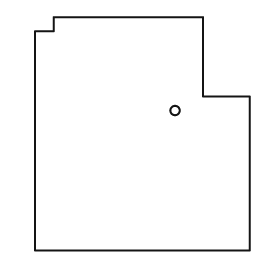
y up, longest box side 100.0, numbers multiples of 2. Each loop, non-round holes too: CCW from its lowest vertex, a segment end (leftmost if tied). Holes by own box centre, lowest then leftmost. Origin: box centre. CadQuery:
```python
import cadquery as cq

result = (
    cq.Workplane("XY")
    .moveTo(-46.0, -50.0)
    .lineTo(46.0, -50.0)
    .lineTo(46.0, 16.0)
    .lineTo(26.0, 16.0)
    .lineTo(26.0, 50.0)
    .lineTo(-38.0, 50.0)
    .lineTo(-38.0, 44.0)
    .lineTo(-46.0, 44.0)
    .close()
    .moveTo(14.0, 10.0)
    .circle(2.0)
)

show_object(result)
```